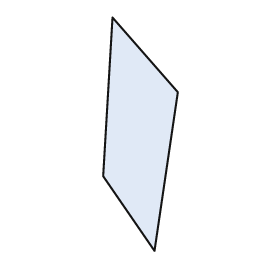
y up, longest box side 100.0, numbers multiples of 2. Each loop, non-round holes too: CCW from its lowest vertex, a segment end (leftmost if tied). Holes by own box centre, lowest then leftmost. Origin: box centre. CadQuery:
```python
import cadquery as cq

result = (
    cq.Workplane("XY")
    .moveTo(6.0, -50.0)
    .lineTo(16.0, 18.0)
    .lineTo(-12.0, 50.0)
    .lineTo(-16.0, -18.0)
    .close()
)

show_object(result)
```